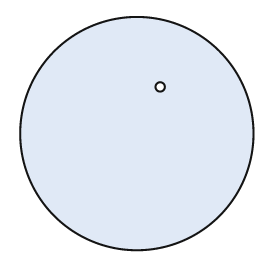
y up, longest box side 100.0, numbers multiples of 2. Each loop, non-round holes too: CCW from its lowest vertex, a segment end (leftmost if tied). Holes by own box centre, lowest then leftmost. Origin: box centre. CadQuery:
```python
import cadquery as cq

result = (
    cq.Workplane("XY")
    .moveTo(0.0, 0.0)
    .circle(50.0)
    .moveTo(10.0, 20.0)
    .circle(2.0)
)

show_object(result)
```